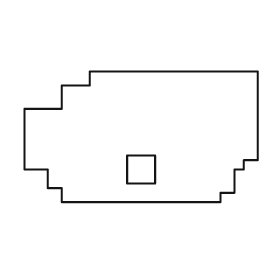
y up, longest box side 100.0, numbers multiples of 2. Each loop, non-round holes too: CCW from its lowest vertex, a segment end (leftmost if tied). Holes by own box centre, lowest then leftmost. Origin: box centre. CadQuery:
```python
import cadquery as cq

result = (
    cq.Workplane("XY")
    .moveTo(-34.0, -28.0)
    .lineTo(34.0, -28.0)
    .lineTo(34.0, -24.0)
    .lineTo(40.0, -24.0)
    .lineTo(40.0, -14.0)
    .lineTo(44.0, -14.0)
    .lineTo(44.0, -10.0)
    .lineTo(50.0, -10.0)
    .lineTo(50.0, 28.0)
    .lineTo(-22.0, 28.0)
    .lineTo(-22.0, 22.0)
    .lineTo(-34.0, 22.0)
    .lineTo(-34.0, 12.0)
    .lineTo(-50.0, 12.0)
    .lineTo(-50.0, -14.0)
    .lineTo(-40.0, -14.0)
    .lineTo(-40.0, -22.0)
    .lineTo(-34.0, -22.0)
    .close()
    .moveTo(-6.0, -20.0)
    .lineTo(6.0, -20.0)
    .lineTo(6.0, -8.0)
    .lineTo(-6.0, -8.0)
    .close()
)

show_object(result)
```